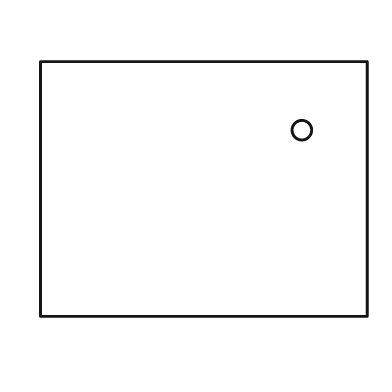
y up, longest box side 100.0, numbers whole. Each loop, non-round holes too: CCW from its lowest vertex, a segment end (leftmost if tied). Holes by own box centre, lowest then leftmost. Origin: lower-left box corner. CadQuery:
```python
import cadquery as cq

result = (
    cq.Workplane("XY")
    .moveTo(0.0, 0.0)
    .lineTo(100.0, 0.0)
    .lineTo(100.0, 78.0)
    .lineTo(0.0, 78.0)
    .close()
    .moveTo(80.0, 57.0)
    .circle(3.0)
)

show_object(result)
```